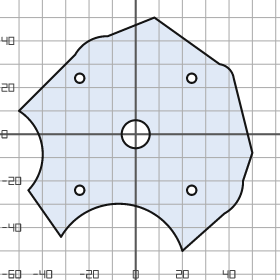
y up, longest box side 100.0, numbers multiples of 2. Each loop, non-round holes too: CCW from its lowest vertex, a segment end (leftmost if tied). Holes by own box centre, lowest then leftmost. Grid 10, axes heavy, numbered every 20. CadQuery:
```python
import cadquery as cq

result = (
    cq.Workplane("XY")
    .moveTo(20.0, -50.0)
    .lineTo(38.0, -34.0)
    .threePointArc((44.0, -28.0), (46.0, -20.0))
    .lineTo(50.0, -8.0)
    .lineTo(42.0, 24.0)
    .threePointArc((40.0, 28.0), (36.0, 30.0))
    .lineTo(8.0, 50.0)
    .lineTo(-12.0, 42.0)
    .threePointArc((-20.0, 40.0), (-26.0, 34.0))
    .lineTo(-50.0, 10.0)
    .threePointArc((-40.0, -6.0), (-46.0, -24.0))
    .lineTo(-32.0, -44.0)
    .threePointArc((-4.0, -30.0), (20.0, -50.0))
    .close()
    .moveTo(-24.0, -24.0)
    .circle(2.0)
    .moveTo(24.0, -24.0)
    .circle(2.0)
    .moveTo(0.0, 0.0)
    .circle(6.0)
    .moveTo(-24.0, 24.0)
    .circle(2.0)
    .moveTo(24.0, 24.0)
    .circle(2.0)
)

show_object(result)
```